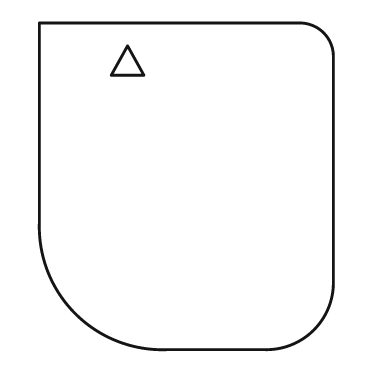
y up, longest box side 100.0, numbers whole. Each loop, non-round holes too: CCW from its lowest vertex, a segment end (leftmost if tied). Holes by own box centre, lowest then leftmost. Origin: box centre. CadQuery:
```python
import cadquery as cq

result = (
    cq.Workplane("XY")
    .moveTo(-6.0, -50.0)
    .lineTo(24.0, -50.0)
    .threePointArc((39.0, -44.0), (45.0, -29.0))
    .lineTo(45.0, 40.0)
    .threePointArc((42.0, 47.0), (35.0, 50.0))
    .lineTo(-45.0, 50.0)
    .lineTo(-45.0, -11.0)
    .threePointArc((-34.0, -39.0), (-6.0, -50.0))
    .close()
    .moveTo(-23.0, 34.0)
    .lineTo(-13.0, 34.0)
    .lineTo(-18.0, 43.0)
    .close()
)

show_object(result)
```